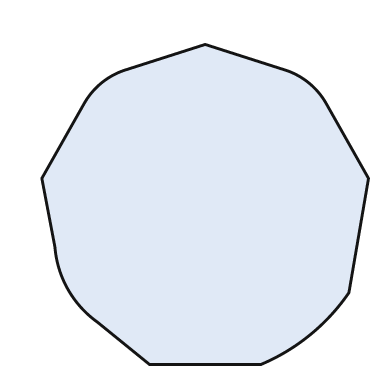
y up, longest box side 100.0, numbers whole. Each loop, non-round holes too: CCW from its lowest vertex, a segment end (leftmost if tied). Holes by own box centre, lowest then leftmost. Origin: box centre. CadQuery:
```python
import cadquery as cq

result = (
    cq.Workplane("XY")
    .moveTo(-17.0, -49.0)
    .lineTo(17.0, -49.0)
    .threePointArc((32.0, -40.0), (44.0, -27.0))
    .lineTo(50.0, 8.0)
    .lineTo(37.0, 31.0)
    .threePointArc((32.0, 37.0), (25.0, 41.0))
    .lineTo(0.0, 49.0)
    .lineTo(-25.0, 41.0)
    .threePointArc((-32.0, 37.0), (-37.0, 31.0))
    .lineTo(-50.0, 8.0)
    .lineTo(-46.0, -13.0)
    .threePointArc((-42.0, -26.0), (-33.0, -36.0))
    .close()
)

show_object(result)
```